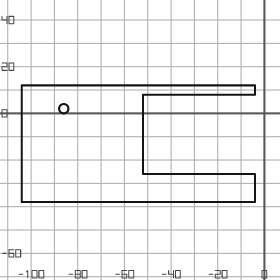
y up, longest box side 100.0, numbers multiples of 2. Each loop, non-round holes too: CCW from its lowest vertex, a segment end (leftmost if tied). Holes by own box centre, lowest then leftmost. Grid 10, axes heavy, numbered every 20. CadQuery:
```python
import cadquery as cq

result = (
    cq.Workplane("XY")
    .moveTo(-104.0, -38.0)
    .lineTo(-4.0, -38.0)
    .lineTo(-4.0, -26.0)
    .lineTo(-52.0, -26.0)
    .lineTo(-52.0, 8.0)
    .lineTo(-4.0, 8.0)
    .lineTo(-4.0, 12.0)
    .lineTo(-104.0, 12.0)
    .close()
    .moveTo(-86.0, 2.0)
    .circle(2.0)
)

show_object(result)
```